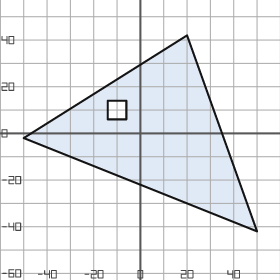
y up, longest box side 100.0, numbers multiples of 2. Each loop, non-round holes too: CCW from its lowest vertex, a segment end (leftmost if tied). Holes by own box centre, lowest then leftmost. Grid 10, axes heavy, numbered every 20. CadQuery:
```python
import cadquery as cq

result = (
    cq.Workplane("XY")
    .moveTo(50.0, -42.0)
    .lineTo(20.0, 42.0)
    .lineTo(-50.0, -2.0)
    .close()
    .moveTo(-14.0, 6.0)
    .lineTo(-6.0, 6.0)
    .lineTo(-6.0, 14.0)
    .lineTo(-14.0, 14.0)
    .close()
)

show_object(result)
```